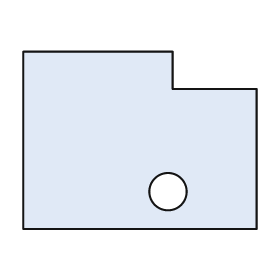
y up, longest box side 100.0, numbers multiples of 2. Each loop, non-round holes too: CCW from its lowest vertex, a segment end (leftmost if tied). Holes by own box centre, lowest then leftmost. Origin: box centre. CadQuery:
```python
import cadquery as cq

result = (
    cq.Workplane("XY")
    .moveTo(-50.0, -38.0)
    .lineTo(50.0, -38.0)
    .lineTo(50.0, 22.0)
    .lineTo(14.0, 22.0)
    .lineTo(14.0, 38.0)
    .lineTo(-50.0, 38.0)
    .close()
    .moveTo(12.0, -22.0)
    .circle(8.0)
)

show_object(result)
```